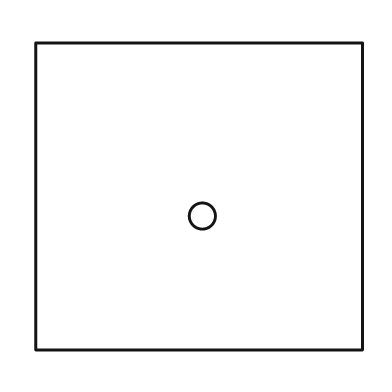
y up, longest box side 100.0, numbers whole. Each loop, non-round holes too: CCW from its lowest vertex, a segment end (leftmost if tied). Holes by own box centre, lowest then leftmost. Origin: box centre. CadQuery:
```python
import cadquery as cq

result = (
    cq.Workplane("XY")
    .moveTo(-50.0, -47.0)
    .lineTo(50.0, -47.0)
    .lineTo(50.0, 47.0)
    .lineTo(-50.0, 47.0)
    .close()
    .moveTo(1.0, -6.0)
    .circle(4.0)
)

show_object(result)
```